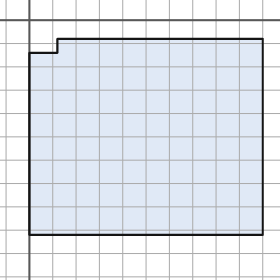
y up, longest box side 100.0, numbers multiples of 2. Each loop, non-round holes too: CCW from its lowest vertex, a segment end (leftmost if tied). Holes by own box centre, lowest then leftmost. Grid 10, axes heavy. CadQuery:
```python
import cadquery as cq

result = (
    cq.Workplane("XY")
    .moveTo(0.0, -92.0)
    .lineTo(100.0, -92.0)
    .lineTo(100.0, -8.0)
    .lineTo(12.0, -8.0)
    .lineTo(12.0, -14.0)
    .lineTo(0.0, -14.0)
    .close()
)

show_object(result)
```